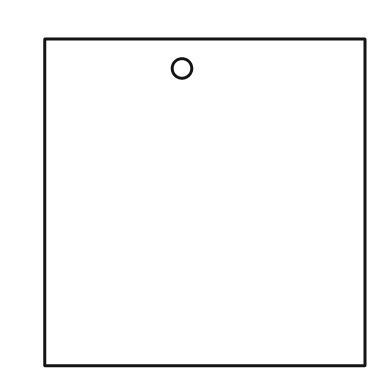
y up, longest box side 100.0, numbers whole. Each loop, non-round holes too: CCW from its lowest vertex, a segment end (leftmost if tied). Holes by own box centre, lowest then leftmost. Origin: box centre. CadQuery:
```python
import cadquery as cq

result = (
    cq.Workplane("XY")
    .moveTo(-49.0, -50.0)
    .lineTo(49.0, -50.0)
    .lineTo(49.0, 50.0)
    .lineTo(-49.0, 50.0)
    .close()
    .moveTo(-7.0, 41.0)
    .circle(3.0)
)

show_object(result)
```